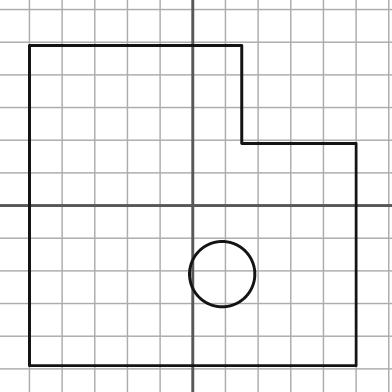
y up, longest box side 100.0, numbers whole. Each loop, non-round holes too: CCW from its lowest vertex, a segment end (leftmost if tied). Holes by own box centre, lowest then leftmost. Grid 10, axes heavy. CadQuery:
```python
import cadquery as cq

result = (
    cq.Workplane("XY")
    .moveTo(-50.0, -49.0)
    .lineTo(50.0, -49.0)
    .lineTo(50.0, 19.0)
    .lineTo(15.0, 19.0)
    .lineTo(15.0, 49.0)
    .lineTo(-50.0, 49.0)
    .close()
    .moveTo(9.0, -21.0)
    .circle(10.0)
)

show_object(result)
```